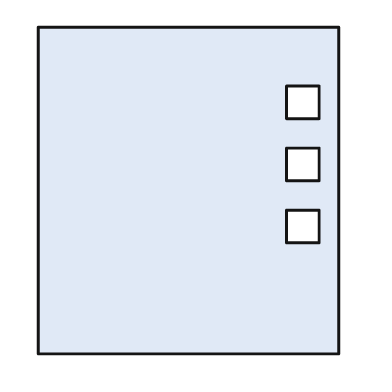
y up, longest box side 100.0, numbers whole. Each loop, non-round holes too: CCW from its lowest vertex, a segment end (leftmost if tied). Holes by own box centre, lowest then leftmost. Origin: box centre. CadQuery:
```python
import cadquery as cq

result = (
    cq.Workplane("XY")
    .moveTo(-46.0, -50.0)
    .lineTo(46.0, -50.0)
    .lineTo(46.0, 50.0)
    .lineTo(-46.0, 50.0)
    .close()
    .moveTo(30.0, -16.0)
    .lineTo(40.0, -16.0)
    .lineTo(40.0, -6.0)
    .lineTo(30.0, -6.0)
    .close()
    .moveTo(30.0, 3.0)
    .lineTo(40.0, 3.0)
    .lineTo(40.0, 13.0)
    .lineTo(30.0, 13.0)
    .close()
    .moveTo(30.0, 22.0)
    .lineTo(40.0, 22.0)
    .lineTo(40.0, 32.0)
    .lineTo(30.0, 32.0)
    .close()
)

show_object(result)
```